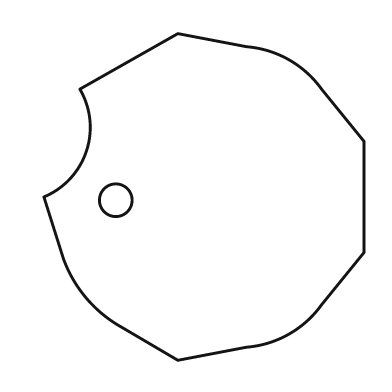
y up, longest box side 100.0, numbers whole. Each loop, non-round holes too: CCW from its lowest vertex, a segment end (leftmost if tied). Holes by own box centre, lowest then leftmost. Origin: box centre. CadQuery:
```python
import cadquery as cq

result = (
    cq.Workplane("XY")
    .moveTo(-8.0, -50.0)
    .lineTo(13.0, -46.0)
    .threePointArc((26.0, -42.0), (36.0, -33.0))
    .lineTo(49.0, -17.0)
    .lineTo(49.0, 17.0)
    .lineTo(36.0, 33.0)
    .threePointArc((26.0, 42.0), (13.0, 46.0))
    .lineTo(-8.0, 50.0)
    .lineTo(-38.0, 33.0)
    .threePointArc((-36.0, 14.0), (-49.0, 0.0))
    .lineTo(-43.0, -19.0)
    .threePointArc((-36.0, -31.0), (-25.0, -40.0))
    .close()
    .moveTo(-27.0, -1.0)
    .circle(5.0)
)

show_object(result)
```